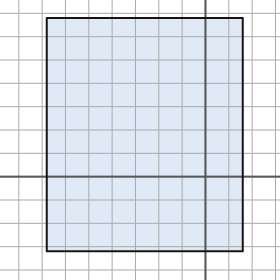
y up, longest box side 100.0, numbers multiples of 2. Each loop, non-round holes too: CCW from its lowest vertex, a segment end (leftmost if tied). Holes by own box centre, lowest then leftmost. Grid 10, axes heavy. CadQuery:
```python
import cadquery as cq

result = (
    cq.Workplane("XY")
    .moveTo(-68.0, -32.0)
    .lineTo(16.0, -32.0)
    .lineTo(16.0, 68.0)
    .lineTo(-68.0, 68.0)
    .close()
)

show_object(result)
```